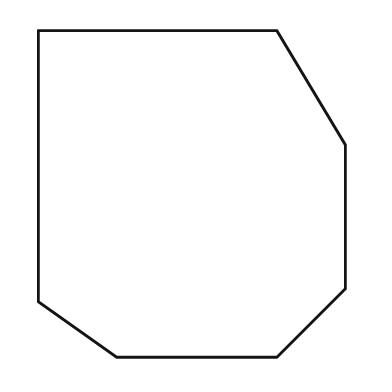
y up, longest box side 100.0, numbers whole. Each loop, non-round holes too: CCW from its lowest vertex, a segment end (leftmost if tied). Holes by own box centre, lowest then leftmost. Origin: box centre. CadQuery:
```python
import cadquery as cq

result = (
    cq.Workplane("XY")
    .moveTo(-23.0, -50.0)
    .lineTo(26.0, -50.0)
    .lineTo(47.0, -29.0)
    .lineTo(47.0, 15.0)
    .lineTo(26.0, 50.0)
    .lineTo(-47.0, 50.0)
    .lineTo(-47.0, -33.0)
    .close()
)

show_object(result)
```